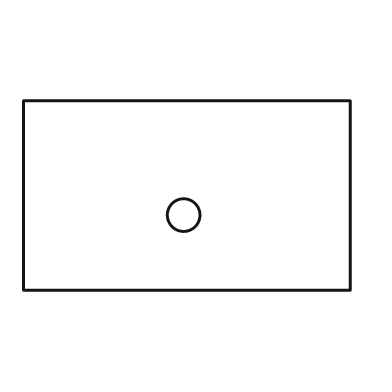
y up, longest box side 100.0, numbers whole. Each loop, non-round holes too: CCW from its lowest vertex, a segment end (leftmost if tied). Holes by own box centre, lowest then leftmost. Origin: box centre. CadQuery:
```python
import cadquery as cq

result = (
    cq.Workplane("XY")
    .moveTo(-50.0, -29.0)
    .lineTo(50.0, -29.0)
    .lineTo(50.0, 29.0)
    .lineTo(-50.0, 29.0)
    .close()
    .moveTo(-1.0, -6.0)
    .circle(5.0)
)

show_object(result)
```